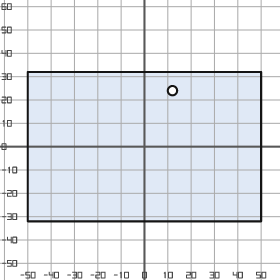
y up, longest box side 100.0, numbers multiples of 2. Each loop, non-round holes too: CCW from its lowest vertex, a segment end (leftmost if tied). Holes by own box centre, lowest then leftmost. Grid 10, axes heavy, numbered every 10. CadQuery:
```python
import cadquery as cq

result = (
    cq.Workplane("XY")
    .moveTo(-50.0, -32.0)
    .lineTo(50.0, -32.0)
    .lineTo(50.0, 32.0)
    .lineTo(-50.0, 32.0)
    .close()
    .moveTo(12.0, 24.0)
    .circle(2.0)
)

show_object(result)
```